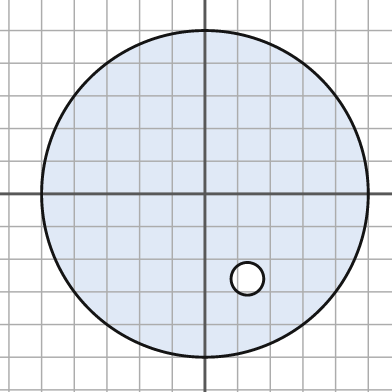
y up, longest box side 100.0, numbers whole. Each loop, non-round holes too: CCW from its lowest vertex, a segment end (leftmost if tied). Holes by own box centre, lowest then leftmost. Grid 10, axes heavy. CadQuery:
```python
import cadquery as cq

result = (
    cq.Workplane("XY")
    .moveTo(0.0, 0.0)
    .circle(50.0)
    .moveTo(13.0, -26.0)
    .circle(5.0)
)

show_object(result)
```